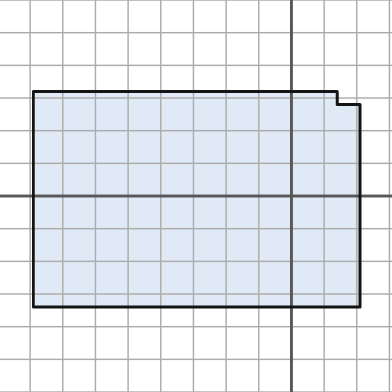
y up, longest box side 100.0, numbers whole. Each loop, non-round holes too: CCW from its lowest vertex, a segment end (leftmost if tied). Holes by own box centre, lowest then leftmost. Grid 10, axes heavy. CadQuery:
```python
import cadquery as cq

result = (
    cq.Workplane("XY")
    .moveTo(-79.0, -34.0)
    .lineTo(21.0, -34.0)
    .lineTo(21.0, 28.0)
    .lineTo(14.0, 28.0)
    .lineTo(14.0, 32.0)
    .lineTo(-79.0, 32.0)
    .close()
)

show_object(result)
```